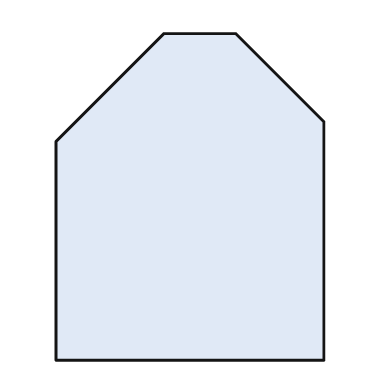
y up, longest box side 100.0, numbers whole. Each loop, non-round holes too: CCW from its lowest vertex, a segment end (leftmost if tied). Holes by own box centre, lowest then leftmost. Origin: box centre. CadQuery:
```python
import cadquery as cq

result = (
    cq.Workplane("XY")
    .moveTo(-41.0, -50.0)
    .lineTo(41.0, -50.0)
    .lineTo(41.0, 23.0)
    .lineTo(14.0, 50.0)
    .lineTo(-8.0, 50.0)
    .lineTo(-41.0, 17.0)
    .close()
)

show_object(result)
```